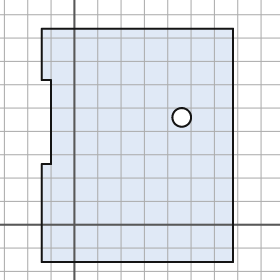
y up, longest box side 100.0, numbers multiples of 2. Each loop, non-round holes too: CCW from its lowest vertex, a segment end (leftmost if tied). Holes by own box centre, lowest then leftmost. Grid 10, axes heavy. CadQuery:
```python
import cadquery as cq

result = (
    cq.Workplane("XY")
    .moveTo(-14.0, -16.0)
    .lineTo(68.0, -16.0)
    .lineTo(68.0, 84.0)
    .lineTo(-14.0, 84.0)
    .lineTo(-14.0, 62.0)
    .lineTo(-10.0, 62.0)
    .lineTo(-10.0, 26.0)
    .lineTo(-14.0, 26.0)
    .close()
    .moveTo(46.0, 46.0)
    .circle(4.0)
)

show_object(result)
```